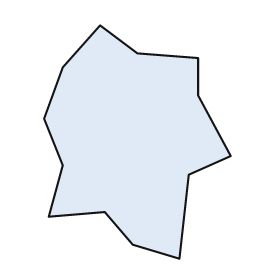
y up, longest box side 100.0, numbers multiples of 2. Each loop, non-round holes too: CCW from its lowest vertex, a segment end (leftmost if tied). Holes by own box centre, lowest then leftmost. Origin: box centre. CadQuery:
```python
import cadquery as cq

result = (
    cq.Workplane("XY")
    .moveTo(18.0, -50.0)
    .lineTo(22.0, -14.0)
    .lineTo(40.0, -6.0)
    .lineTo(26.0, 20.0)
    .lineTo(26.0, 36.0)
    .lineTo(0.0, 38.0)
    .lineTo(-16.0, 50.0)
    .lineTo(-32.0, 32.0)
    .lineTo(-40.0, 10.0)
    .lineTo(-32.0, -10.0)
    .lineTo(-38.0, -32.0)
    .lineTo(-14.0, -30.0)
    .lineTo(-2.0, -44.0)
    .close()
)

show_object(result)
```